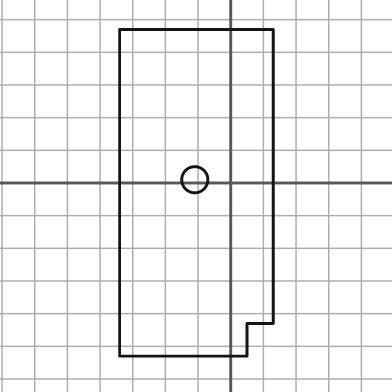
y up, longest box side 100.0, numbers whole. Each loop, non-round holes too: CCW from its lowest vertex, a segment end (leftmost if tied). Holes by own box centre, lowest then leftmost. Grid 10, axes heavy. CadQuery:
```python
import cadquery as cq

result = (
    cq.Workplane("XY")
    .moveTo(-34.0, -53.0)
    .lineTo(5.0, -53.0)
    .lineTo(5.0, -43.0)
    .lineTo(13.0, -43.0)
    .lineTo(13.0, 47.0)
    .lineTo(-34.0, 47.0)
    .close()
    .moveTo(-11.0, 1.0)
    .circle(4.0)
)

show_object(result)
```